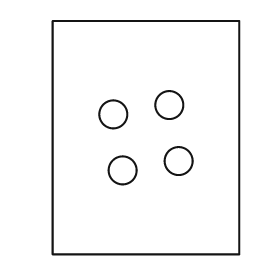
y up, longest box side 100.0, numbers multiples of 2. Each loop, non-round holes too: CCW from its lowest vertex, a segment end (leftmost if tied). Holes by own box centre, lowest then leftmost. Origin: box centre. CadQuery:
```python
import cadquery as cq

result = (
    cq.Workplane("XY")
    .moveTo(-40.0, -50.0)
    .lineTo(40.0, -50.0)
    .lineTo(40.0, 50.0)
    .lineTo(-40.0, 50.0)
    .close()
    .moveTo(-10.0, -14.0)
    .circle(6.0)
    .moveTo(14.0, -10.0)
    .circle(6.0)
    .moveTo(-14.0, 10.0)
    .circle(6.0)
    .moveTo(10.0, 14.0)
    .circle(6.0)
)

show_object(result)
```